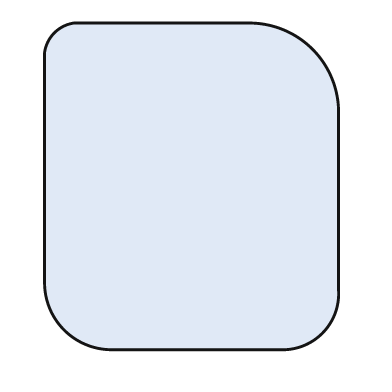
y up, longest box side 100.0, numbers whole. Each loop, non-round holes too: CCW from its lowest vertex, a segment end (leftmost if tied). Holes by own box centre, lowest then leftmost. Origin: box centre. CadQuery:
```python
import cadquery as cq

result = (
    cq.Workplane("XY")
    .moveTo(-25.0, -50.0)
    .lineTo(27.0, -50.0)
    .threePointArc((40.0, -45.0), (45.0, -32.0))
    .lineTo(45.0, 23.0)
    .threePointArc((37.0, 42.0), (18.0, 50.0))
    .lineTo(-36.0, 50.0)
    .threePointArc((-42.0, 47.0), (-45.0, 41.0))
    .lineTo(-45.0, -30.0)
    .threePointArc((-39.0, -44.0), (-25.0, -50.0))
    .close()
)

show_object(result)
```